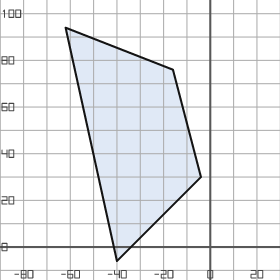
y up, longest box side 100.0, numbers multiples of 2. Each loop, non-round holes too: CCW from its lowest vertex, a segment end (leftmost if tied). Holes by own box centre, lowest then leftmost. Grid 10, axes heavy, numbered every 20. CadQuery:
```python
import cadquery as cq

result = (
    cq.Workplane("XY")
    .moveTo(-40.0, -6.0)
    .lineTo(-4.0, 30.0)
    .lineTo(-16.0, 76.0)
    .lineTo(-62.0, 94.0)
    .close()
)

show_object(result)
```